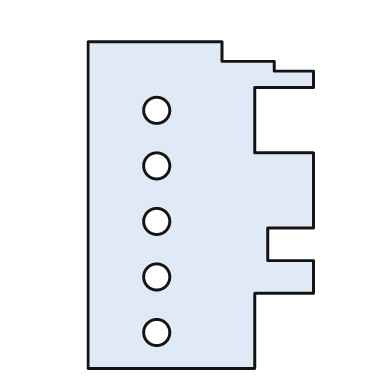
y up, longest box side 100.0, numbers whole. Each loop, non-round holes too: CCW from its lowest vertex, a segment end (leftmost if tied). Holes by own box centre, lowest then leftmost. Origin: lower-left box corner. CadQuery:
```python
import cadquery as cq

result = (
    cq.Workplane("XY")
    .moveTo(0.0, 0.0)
    .lineTo(51.0, 0.0)
    .lineTo(51.0, 23.0)
    .lineTo(69.0, 23.0)
    .lineTo(69.0, 33.0)
    .lineTo(55.0, 33.0)
    .lineTo(55.0, 43.0)
    .lineTo(69.0, 43.0)
    .lineTo(69.0, 66.0)
    .lineTo(51.0, 66.0)
    .lineTo(51.0, 86.0)
    .lineTo(69.0, 86.0)
    .lineTo(69.0, 91.0)
    .lineTo(57.0, 91.0)
    .lineTo(57.0, 94.0)
    .lineTo(41.0, 94.0)
    .lineTo(41.0, 100.0)
    .lineTo(0.0, 100.0)
    .close()
    .moveTo(21.0, 11.0)
    .circle(4.0)
    .moveTo(21.0, 28.0)
    .circle(4.0)
    .moveTo(21.0, 45.0)
    .circle(4.0)
    .moveTo(21.0, 62.0)
    .circle(4.0)
    .moveTo(21.0, 79.0)
    .circle(4.0)
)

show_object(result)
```